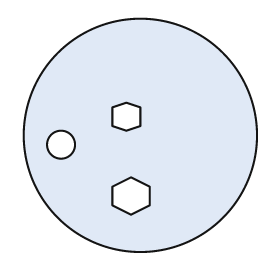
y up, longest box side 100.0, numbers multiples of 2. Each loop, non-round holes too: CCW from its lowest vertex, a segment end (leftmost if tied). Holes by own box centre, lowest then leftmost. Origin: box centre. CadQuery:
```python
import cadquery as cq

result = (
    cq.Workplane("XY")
    .moveTo(0.0, 0.0)
    .circle(50.0)
    .moveTo(-4.0, -34.0)
    .lineTo(4.0, -30.0)
    .lineTo(4.0, -22.0)
    .lineTo(-4.0, -18.0)
    .lineTo(-12.0, -22.0)
    .lineTo(-12.0, -30.0)
    .close()
    .moveTo(-34.0, -4.0)
    .circle(6.0)
    .moveTo(-6.0, 2.0)
    .lineTo(0.0, 4.0)
    .lineTo(0.0, 12.0)
    .lineTo(-6.0, 14.0)
    .lineTo(-12.0, 12.0)
    .lineTo(-12.0, 4.0)
    .close()
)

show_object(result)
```